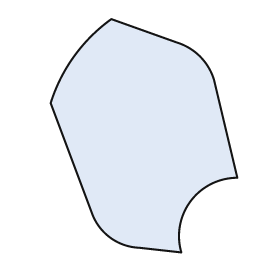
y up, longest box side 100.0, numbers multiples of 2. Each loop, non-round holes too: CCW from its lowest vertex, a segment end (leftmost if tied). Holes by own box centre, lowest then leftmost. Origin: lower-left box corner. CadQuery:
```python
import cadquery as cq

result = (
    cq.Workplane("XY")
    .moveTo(56.0, 0.0)
    .threePointArc((60.0, 22.0), (80.0, 32.0))
    .lineTo(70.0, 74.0)
    .threePointArc((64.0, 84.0), (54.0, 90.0))
    .lineTo(26.0, 100.0)
    .threePointArc((10.0, 84.0), (0.0, 64.0))
    .lineTo(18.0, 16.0)
    .threePointArc((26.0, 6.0), (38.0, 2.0))
    .close()
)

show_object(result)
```